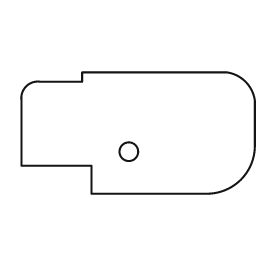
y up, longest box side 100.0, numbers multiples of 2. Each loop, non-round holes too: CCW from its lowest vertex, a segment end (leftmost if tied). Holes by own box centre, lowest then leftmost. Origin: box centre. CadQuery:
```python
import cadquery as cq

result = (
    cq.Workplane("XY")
    .moveTo(-20.0, -26.0)
    .lineTo(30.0, -26.0)
    .threePointArc((44.0, -20.0), (50.0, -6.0))
    .lineTo(50.0, 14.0)
    .threePointArc((46.0, 22.0), (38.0, 26.0))
    .lineTo(-24.0, 26.0)
    .lineTo(-24.0, 22.0)
    .lineTo(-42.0, 22.0)
    .threePointArc((-48.0, 20.0), (-50.0, 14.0))
    .lineTo(-50.0, -14.0)
    .lineTo(-20.0, -14.0)
    .close()
    .moveTo(-4.0, -8.0)
    .circle(4.0)
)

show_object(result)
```